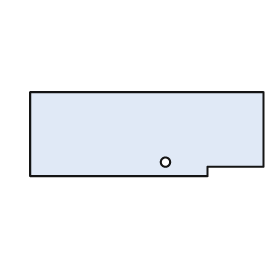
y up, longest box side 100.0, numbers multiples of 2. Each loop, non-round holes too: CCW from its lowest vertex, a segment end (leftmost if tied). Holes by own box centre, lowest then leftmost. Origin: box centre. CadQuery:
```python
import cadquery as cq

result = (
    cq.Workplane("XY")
    .moveTo(-50.0, -18.0)
    .lineTo(26.0, -18.0)
    .lineTo(26.0, -14.0)
    .lineTo(50.0, -14.0)
    .lineTo(50.0, 18.0)
    .lineTo(-50.0, 18.0)
    .close()
    .moveTo(8.0, -12.0)
    .circle(2.0)
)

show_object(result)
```